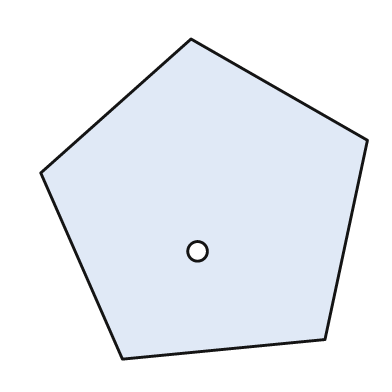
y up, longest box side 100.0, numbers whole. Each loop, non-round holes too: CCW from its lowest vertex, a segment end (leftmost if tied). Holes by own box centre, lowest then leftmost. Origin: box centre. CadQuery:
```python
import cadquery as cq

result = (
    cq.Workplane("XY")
    .moveTo(-25.0, -49.0)
    .lineTo(37.0, -43.0)
    .lineTo(50.0, 18.0)
    .lineTo(-4.0, 49.0)
    .lineTo(-50.0, 8.0)
    .close()
    .moveTo(-2.0, -16.0)
    .circle(3.0)
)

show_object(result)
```